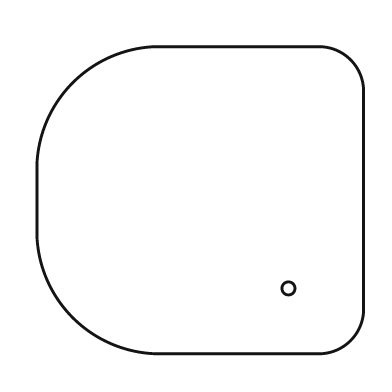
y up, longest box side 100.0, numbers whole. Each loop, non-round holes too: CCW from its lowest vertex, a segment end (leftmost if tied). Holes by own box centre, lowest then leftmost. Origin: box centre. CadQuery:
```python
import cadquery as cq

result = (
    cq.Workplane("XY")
    .moveTo(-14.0, -47.0)
    .lineTo(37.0, -47.0)
    .threePointArc((46.0, -43.0), (50.0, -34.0))
    .lineTo(50.0, 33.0)
    .threePointArc((46.0, 43.0), (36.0, 47.0))
    .lineTo(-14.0, 47.0)
    .threePointArc((-39.0, 36.0), (-50.0, 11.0))
    .lineTo(-50.0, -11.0)
    .threePointArc((-39.0, -36.0), (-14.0, -47.0))
    .close()
    .moveTo(27.0, -27.0)
    .circle(2.0)
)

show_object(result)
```